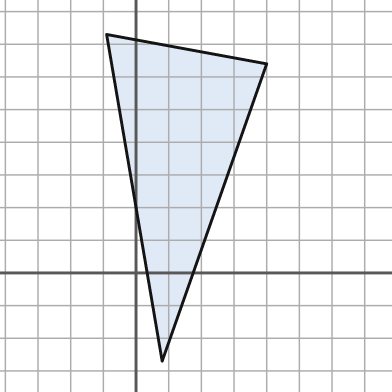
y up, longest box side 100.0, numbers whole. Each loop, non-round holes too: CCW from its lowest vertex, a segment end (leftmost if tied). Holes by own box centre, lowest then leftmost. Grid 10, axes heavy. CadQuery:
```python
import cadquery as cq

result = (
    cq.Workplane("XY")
    .moveTo(8.0, -27.0)
    .lineTo(40.0, 64.0)
    .lineTo(-9.0, 73.0)
    .close()
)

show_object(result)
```